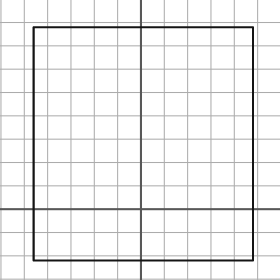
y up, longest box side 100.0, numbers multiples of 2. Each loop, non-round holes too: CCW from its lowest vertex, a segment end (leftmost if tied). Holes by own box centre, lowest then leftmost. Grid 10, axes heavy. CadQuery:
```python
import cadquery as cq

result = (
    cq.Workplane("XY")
    .moveTo(-46.0, -22.0)
    .lineTo(48.0, -22.0)
    .lineTo(48.0, 78.0)
    .lineTo(-46.0, 78.0)
    .close()
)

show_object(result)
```